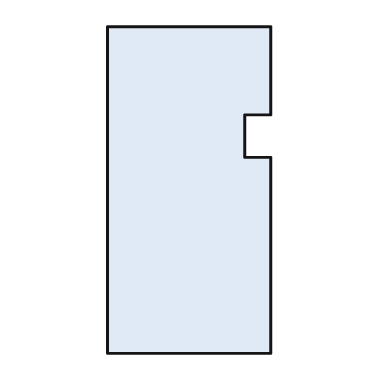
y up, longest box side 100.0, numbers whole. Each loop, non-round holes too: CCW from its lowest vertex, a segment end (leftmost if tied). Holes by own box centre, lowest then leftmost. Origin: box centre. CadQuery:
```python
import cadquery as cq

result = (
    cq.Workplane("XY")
    .moveTo(-25.0, -50.0)
    .lineTo(25.0, -50.0)
    .lineTo(25.0, 10.0)
    .lineTo(17.0, 10.0)
    .lineTo(17.0, 23.0)
    .lineTo(25.0, 23.0)
    .lineTo(25.0, 50.0)
    .lineTo(-25.0, 50.0)
    .close()
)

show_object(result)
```